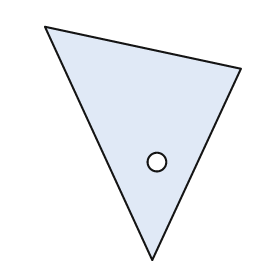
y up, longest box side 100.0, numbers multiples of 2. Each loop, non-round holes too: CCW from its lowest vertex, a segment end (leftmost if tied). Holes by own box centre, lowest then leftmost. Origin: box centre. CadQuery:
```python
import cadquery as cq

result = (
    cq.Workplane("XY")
    .moveTo(4.0, -50.0)
    .lineTo(42.0, 32.0)
    .lineTo(-42.0, 50.0)
    .close()
    .moveTo(6.0, -8.0)
    .circle(4.0)
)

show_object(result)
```